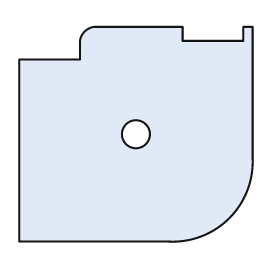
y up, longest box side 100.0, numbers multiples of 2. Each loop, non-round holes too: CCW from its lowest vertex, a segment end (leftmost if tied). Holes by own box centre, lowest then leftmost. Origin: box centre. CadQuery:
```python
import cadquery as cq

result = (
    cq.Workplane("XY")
    .moveTo(-50.0, -46.0)
    .lineTo(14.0, -46.0)
    .threePointArc((40.0, -36.0), (50.0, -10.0))
    .lineTo(50.0, 46.0)
    .lineTo(46.0, 46.0)
    .lineTo(46.0, 40.0)
    .lineTo(20.0, 40.0)
    .lineTo(20.0, 46.0)
    .lineTo(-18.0, 46.0)
    .threePointArc((-22.0, 44.0), (-24.0, 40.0))
    .lineTo(-24.0, 32.0)
    .lineTo(-50.0, 32.0)
    .close()
    .moveTo(0.0, 0.0)
    .circle(6.0)
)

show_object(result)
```